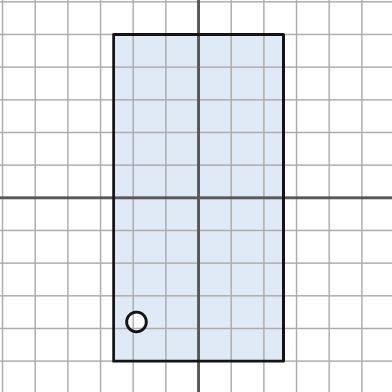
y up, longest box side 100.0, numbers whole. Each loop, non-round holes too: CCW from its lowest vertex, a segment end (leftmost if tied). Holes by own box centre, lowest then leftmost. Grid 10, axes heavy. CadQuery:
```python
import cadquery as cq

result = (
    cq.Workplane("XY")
    .moveTo(-26.0, -50.0)
    .lineTo(26.0, -50.0)
    .lineTo(26.0, 50.0)
    .lineTo(-26.0, 50.0)
    .close()
    .moveTo(-19.0, -38.0)
    .circle(3.0)
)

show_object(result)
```